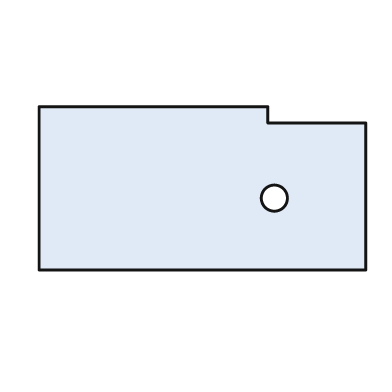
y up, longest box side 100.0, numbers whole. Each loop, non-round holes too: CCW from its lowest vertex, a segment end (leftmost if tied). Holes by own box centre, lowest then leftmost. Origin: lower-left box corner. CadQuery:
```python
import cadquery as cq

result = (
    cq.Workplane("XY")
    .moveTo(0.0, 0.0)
    .lineTo(100.0, 0.0)
    .lineTo(100.0, 45.0)
    .lineTo(70.0, 45.0)
    .lineTo(70.0, 50.0)
    .lineTo(0.0, 50.0)
    .close()
    .moveTo(72.0, 22.0)
    .circle(4.0)
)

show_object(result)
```